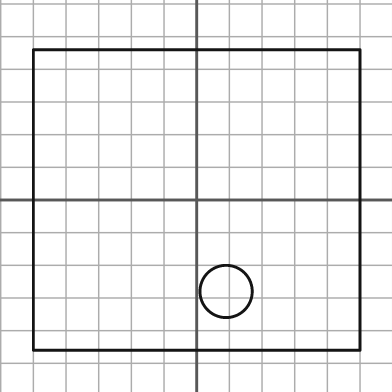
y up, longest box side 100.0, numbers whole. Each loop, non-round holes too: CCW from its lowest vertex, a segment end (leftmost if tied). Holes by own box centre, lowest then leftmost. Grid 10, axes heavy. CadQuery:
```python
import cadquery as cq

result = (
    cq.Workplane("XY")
    .moveTo(-50.0, -46.0)
    .lineTo(50.0, -46.0)
    .lineTo(50.0, 46.0)
    .lineTo(-50.0, 46.0)
    .close()
    .moveTo(9.0, -28.0)
    .circle(8.0)
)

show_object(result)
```